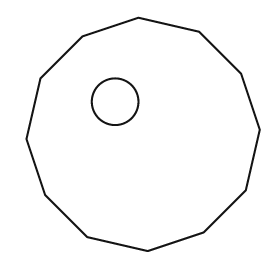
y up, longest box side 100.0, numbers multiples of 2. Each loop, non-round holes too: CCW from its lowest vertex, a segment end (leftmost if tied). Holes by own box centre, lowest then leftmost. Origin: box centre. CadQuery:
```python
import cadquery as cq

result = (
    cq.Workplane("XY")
    .moveTo(2.0, -50.0)
    .lineTo(26.0, -42.0)
    .lineTo(44.0, -24.0)
    .lineTo(50.0, 2.0)
    .lineTo(42.0, 26.0)
    .lineTo(24.0, 44.0)
    .lineTo(-2.0, 50.0)
    .lineTo(-26.0, 42.0)
    .lineTo(-44.0, 24.0)
    .lineTo(-50.0, -2.0)
    .lineTo(-42.0, -26.0)
    .lineTo(-24.0, -44.0)
    .close()
    .moveTo(-12.0, 14.0)
    .circle(10.0)
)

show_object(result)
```